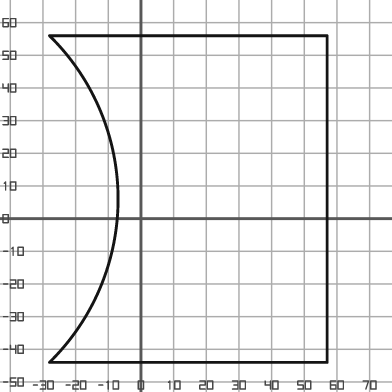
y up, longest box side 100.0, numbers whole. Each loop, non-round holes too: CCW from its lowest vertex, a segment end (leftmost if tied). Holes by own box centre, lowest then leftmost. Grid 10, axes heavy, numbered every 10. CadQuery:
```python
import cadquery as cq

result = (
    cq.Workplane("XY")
    .moveTo(-28.0, -44.0)
    .lineTo(57.0, -44.0)
    .lineTo(57.0, 56.0)
    .lineTo(-28.0, 56.0)
    .threePointArc((-7.0, 6.0), (-28.0, -44.0))
    .close()
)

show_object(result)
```